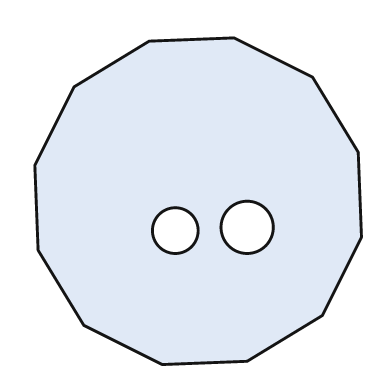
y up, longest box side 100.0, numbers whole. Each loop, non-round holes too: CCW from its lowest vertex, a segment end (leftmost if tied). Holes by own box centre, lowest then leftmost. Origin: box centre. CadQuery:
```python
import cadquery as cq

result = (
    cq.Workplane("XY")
    .moveTo(-11.0, -50.0)
    .lineTo(15.0, -49.0)
    .lineTo(38.0, -35.0)
    .lineTo(50.0, -11.0)
    .lineTo(49.0, 15.0)
    .lineTo(35.0, 38.0)
    .lineTo(11.0, 50.0)
    .lineTo(-15.0, 49.0)
    .lineTo(-38.0, 35.0)
    .lineTo(-50.0, 11.0)
    .lineTo(-49.0, -15.0)
    .lineTo(-35.0, -38.0)
    .close()
    .moveTo(-7.0, -9.0)
    .circle(7.0)
    .moveTo(15.0, -8.0)
    .circle(8.0)
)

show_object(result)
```